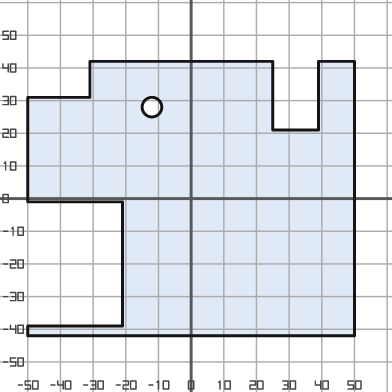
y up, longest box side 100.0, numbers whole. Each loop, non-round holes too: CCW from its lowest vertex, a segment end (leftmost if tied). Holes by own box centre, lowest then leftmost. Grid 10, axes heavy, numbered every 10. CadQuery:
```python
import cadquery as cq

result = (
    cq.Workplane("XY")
    .moveTo(-50.0, -42.0)
    .lineTo(50.0, -42.0)
    .lineTo(50.0, 42.0)
    .lineTo(39.0, 42.0)
    .lineTo(39.0, 21.0)
    .lineTo(25.0, 21.0)
    .lineTo(25.0, 42.0)
    .lineTo(-31.0, 42.0)
    .lineTo(-31.0, 31.0)
    .lineTo(-50.0, 31.0)
    .lineTo(-50.0, -1.0)
    .lineTo(-21.0, -1.0)
    .lineTo(-21.0, -39.0)
    .lineTo(-50.0, -39.0)
    .close()
    .moveTo(-12.0, 28.0)
    .circle(3.0)
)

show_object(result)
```